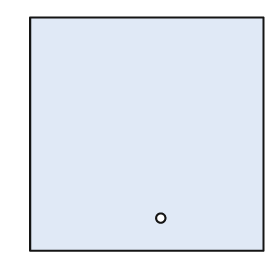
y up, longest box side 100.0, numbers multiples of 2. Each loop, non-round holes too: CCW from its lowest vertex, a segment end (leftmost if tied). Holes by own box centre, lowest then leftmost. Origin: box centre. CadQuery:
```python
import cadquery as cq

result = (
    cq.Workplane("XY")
    .moveTo(-50.0, -50.0)
    .lineTo(50.0, -50.0)
    .lineTo(50.0, 50.0)
    .lineTo(-50.0, 50.0)
    .close()
    .moveTo(6.0, -36.0)
    .circle(2.0)
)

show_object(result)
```